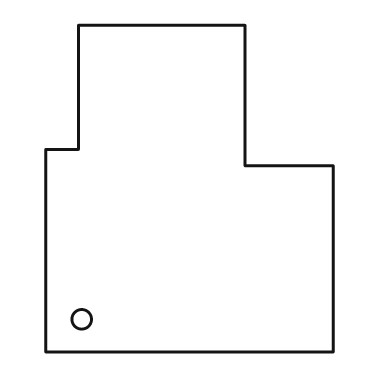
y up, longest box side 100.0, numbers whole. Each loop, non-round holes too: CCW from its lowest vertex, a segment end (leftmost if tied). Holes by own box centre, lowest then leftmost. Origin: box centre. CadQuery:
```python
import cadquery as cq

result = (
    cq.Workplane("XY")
    .moveTo(-44.0, -50.0)
    .lineTo(44.0, -50.0)
    .lineTo(44.0, 7.0)
    .lineTo(17.0, 7.0)
    .lineTo(17.0, 50.0)
    .lineTo(-34.0, 50.0)
    .lineTo(-34.0, 12.0)
    .lineTo(-44.0, 12.0)
    .close()
    .moveTo(-33.0, -40.0)
    .circle(3.0)
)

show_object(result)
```